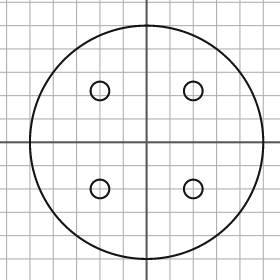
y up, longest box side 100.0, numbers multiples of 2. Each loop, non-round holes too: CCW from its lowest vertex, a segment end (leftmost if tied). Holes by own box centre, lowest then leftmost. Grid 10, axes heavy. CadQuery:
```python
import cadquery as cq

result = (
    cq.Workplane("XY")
    .moveTo(0.0, 0.0)
    .circle(50.0)
    .moveTo(-20.0, -20.0)
    .circle(4.0)
    .moveTo(20.0, -20.0)
    .circle(4.0)
    .moveTo(-20.0, 22.0)
    .circle(4.0)
    .moveTo(20.0, 22.0)
    .circle(4.0)
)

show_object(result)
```